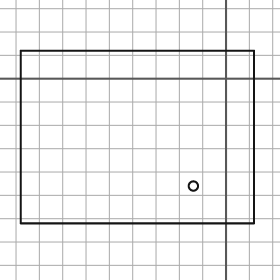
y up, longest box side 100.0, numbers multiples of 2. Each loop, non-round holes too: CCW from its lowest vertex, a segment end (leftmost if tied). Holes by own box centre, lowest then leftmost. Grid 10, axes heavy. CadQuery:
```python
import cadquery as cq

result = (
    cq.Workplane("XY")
    .moveTo(-88.0, -62.0)
    .lineTo(12.0, -62.0)
    .lineTo(12.0, 12.0)
    .lineTo(-88.0, 12.0)
    .close()
    .moveTo(-14.0, -46.0)
    .circle(2.0)
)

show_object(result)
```